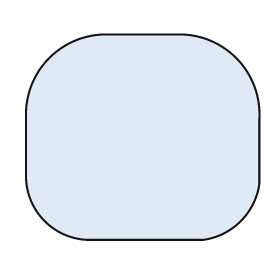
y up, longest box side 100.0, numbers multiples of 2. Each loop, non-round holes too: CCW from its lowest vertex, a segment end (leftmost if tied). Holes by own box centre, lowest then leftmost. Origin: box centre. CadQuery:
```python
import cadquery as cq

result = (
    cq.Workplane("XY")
    .moveTo(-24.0, -44.0)
    .lineTo(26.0, -44.0)
    .threePointArc((42.0, -36.0), (50.0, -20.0))
    .lineTo(50.0, 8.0)
    .threePointArc((40.0, 34.0), (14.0, 44.0))
    .lineTo(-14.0, 44.0)
    .threePointArc((-40.0, 34.0), (-50.0, 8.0))
    .lineTo(-50.0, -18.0)
    .threePointArc((-42.0, -36.0), (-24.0, -44.0))
    .close()
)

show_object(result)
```